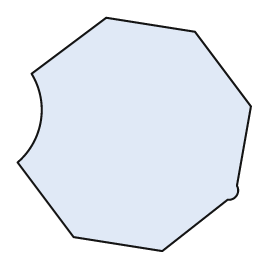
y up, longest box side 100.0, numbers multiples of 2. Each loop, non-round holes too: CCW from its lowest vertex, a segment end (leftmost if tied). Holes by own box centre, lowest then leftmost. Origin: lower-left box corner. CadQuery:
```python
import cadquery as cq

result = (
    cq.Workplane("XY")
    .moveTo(62.0, 0.0)
    .lineTo(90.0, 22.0)
    .threePointArc((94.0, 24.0), (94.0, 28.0))
    .lineTo(100.0, 62.0)
    .lineTo(76.0, 94.0)
    .lineTo(38.0, 100.0)
    .lineTo(6.0, 76.0)
    .threePointArc((10.0, 56.0), (0.0, 38.0))
    .lineTo(24.0, 6.0)
    .close()
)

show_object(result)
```